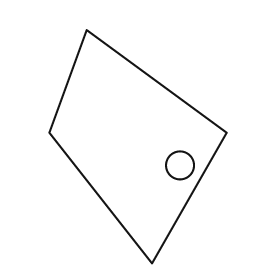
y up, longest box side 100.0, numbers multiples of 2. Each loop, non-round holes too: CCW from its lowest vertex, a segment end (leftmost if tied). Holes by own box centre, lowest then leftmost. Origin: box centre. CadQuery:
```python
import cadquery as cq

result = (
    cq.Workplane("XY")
    .moveTo(6.0, -50.0)
    .lineTo(38.0, 6.0)
    .lineTo(-22.0, 50.0)
    .lineTo(-38.0, 6.0)
    .close()
    .moveTo(18.0, -8.0)
    .circle(6.0)
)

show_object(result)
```